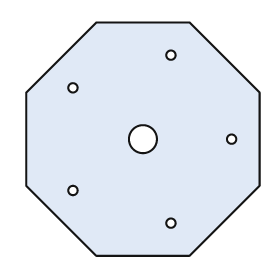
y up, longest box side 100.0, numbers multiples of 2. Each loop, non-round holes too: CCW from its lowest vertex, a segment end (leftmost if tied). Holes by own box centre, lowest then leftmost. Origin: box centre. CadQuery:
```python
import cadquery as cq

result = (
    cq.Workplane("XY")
    .moveTo(-20.0, -50.0)
    .lineTo(20.0, -50.0)
    .lineTo(50.0, -20.0)
    .lineTo(50.0, 20.0)
    .lineTo(20.0, 50.0)
    .lineTo(-20.0, 50.0)
    .lineTo(-50.0, 20.0)
    .lineTo(-50.0, -20.0)
    .close()
    .moveTo(12.0, -36.0)
    .circle(2.0)
    .moveTo(-30.0, -22.0)
    .circle(2.0)
    .moveTo(0.0, 0.0)
    .circle(6.0)
    .moveTo(38.0, 0.0)
    .circle(2.0)
    .moveTo(-30.0, 22.0)
    .circle(2.0)
    .moveTo(12.0, 36.0)
    .circle(2.0)
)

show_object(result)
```